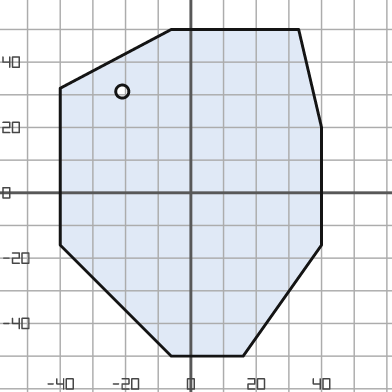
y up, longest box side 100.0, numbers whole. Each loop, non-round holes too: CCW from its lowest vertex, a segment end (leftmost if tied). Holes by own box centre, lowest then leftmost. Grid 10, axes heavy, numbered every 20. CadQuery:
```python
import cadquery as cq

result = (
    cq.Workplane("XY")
    .moveTo(-6.0, -50.0)
    .lineTo(16.0, -50.0)
    .lineTo(40.0, -16.0)
    .lineTo(40.0, 20.0)
    .lineTo(33.0, 50.0)
    .lineTo(-6.0, 50.0)
    .lineTo(-40.0, 32.0)
    .lineTo(-40.0, -16.0)
    .close()
    .moveTo(-21.0, 31.0)
    .circle(2.0)
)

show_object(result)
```